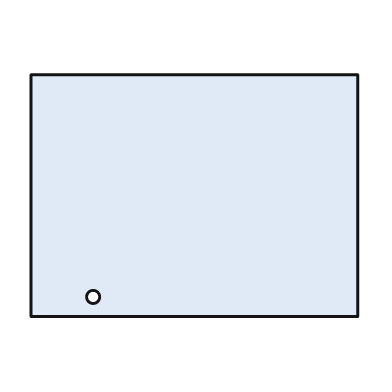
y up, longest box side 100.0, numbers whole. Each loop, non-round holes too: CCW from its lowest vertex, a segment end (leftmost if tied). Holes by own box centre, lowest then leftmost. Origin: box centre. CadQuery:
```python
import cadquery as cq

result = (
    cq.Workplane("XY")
    .moveTo(-50.0, -37.0)
    .lineTo(50.0, -37.0)
    .lineTo(50.0, 37.0)
    .lineTo(-50.0, 37.0)
    .close()
    .moveTo(-31.0, -31.0)
    .circle(2.0)
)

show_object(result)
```